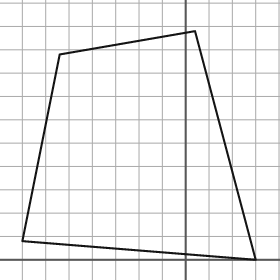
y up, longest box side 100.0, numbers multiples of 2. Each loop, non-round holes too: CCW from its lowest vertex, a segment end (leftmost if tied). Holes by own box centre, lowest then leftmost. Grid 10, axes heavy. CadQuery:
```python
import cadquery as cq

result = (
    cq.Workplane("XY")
    .moveTo(30.0, 0.0)
    .lineTo(4.0, 98.0)
    .lineTo(-54.0, 88.0)
    .lineTo(-70.0, 8.0)
    .close()
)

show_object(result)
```